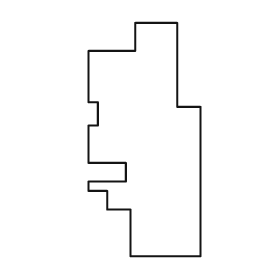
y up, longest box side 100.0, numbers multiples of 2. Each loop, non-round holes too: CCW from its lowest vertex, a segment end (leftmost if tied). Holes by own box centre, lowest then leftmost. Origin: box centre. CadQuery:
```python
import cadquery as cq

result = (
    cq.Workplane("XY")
    .moveTo(-6.0, -50.0)
    .lineTo(24.0, -50.0)
    .lineTo(24.0, 14.0)
    .lineTo(14.0, 14.0)
    .lineTo(14.0, 50.0)
    .lineTo(-4.0, 50.0)
    .lineTo(-4.0, 38.0)
    .lineTo(-24.0, 38.0)
    .lineTo(-24.0, 16.0)
    .lineTo(-20.0, 16.0)
    .lineTo(-20.0, 6.0)
    .lineTo(-24.0, 6.0)
    .lineTo(-24.0, -10.0)
    .lineTo(-8.0, -10.0)
    .lineTo(-8.0, -18.0)
    .lineTo(-24.0, -18.0)
    .lineTo(-24.0, -22.0)
    .lineTo(-16.0, -22.0)
    .lineTo(-16.0, -30.0)
    .lineTo(-6.0, -30.0)
    .close()
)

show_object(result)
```